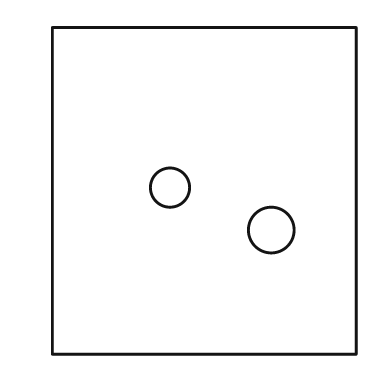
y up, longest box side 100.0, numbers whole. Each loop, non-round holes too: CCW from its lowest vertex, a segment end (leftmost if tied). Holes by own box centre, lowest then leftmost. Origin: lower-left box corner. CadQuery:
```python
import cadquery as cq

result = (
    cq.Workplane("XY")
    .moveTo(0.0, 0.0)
    .lineTo(93.0, 0.0)
    .lineTo(93.0, 100.0)
    .lineTo(0.0, 100.0)
    .close()
    .moveTo(67.0, 38.0)
    .circle(7.0)
    .moveTo(36.0, 51.0)
    .circle(6.0)
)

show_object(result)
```